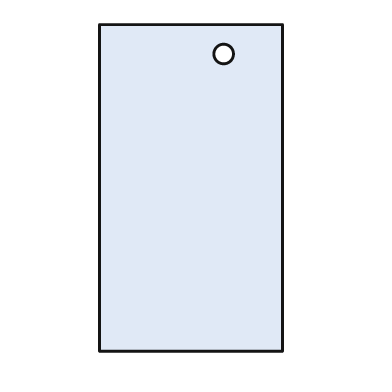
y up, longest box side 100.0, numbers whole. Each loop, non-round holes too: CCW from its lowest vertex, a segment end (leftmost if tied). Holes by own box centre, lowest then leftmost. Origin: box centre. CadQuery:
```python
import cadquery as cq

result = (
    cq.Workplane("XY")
    .moveTo(-28.0, -50.0)
    .lineTo(28.0, -50.0)
    .lineTo(28.0, 50.0)
    .lineTo(-28.0, 50.0)
    .close()
    .moveTo(10.0, 41.0)
    .circle(3.0)
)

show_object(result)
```